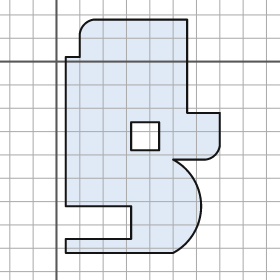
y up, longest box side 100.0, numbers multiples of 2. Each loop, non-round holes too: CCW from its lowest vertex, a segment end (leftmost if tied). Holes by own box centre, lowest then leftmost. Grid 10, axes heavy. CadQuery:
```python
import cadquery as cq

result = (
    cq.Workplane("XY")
    .moveTo(4.0, -82.0)
    .lineTo(50.0, -82.0)
    .threePointArc((62.0, -62.0), (50.0, -42.0))
    .lineTo(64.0, -42.0)
    .threePointArc((68.0, -40.0), (70.0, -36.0))
    .lineTo(70.0, -22.0)
    .lineTo(56.0, -22.0)
    .lineTo(56.0, 18.0)
    .lineTo(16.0, 18.0)
    .threePointArc((12.0, 16.0), (10.0, 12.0))
    .lineTo(10.0, 2.0)
    .lineTo(4.0, 2.0)
    .lineTo(4.0, -62.0)
    .lineTo(32.0, -62.0)
    .lineTo(32.0, -76.0)
    .lineTo(4.0, -76.0)
    .close()
    .moveTo(32.0, -38.0)
    .lineTo(44.0, -38.0)
    .lineTo(44.0, -26.0)
    .lineTo(32.0, -26.0)
    .close()
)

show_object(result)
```